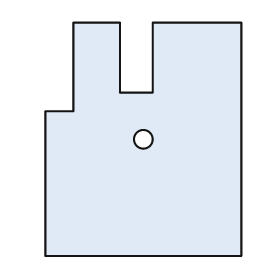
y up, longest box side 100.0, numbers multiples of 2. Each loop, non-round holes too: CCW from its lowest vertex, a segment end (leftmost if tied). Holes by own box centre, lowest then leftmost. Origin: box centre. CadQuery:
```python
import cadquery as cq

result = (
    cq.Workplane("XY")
    .moveTo(-42.0, -50.0)
    .lineTo(42.0, -50.0)
    .lineTo(42.0, 50.0)
    .lineTo(4.0, 50.0)
    .lineTo(4.0, 20.0)
    .lineTo(-10.0, 20.0)
    .lineTo(-10.0, 50.0)
    .lineTo(-30.0, 50.0)
    .lineTo(-30.0, 12.0)
    .lineTo(-42.0, 12.0)
    .close()
    .moveTo(0.0, 0.0)
    .circle(4.0)
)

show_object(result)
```